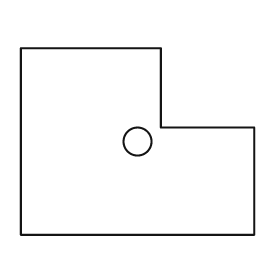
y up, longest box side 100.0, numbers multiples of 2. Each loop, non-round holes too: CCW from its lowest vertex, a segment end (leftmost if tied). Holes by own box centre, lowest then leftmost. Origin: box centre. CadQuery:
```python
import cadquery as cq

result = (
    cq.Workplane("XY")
    .moveTo(-50.0, -40.0)
    .lineTo(50.0, -40.0)
    .lineTo(50.0, 6.0)
    .lineTo(10.0, 6.0)
    .lineTo(10.0, 40.0)
    .lineTo(-50.0, 40.0)
    .close()
    .moveTo(0.0, 0.0)
    .circle(6.0)
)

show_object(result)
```